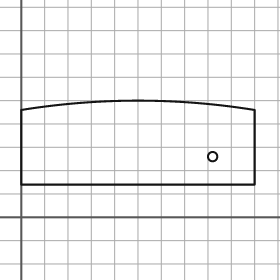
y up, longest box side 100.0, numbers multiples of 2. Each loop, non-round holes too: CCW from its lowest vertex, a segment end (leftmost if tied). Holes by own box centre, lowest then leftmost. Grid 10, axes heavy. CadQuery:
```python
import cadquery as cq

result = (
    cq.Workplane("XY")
    .moveTo(0.0, 14.0)
    .lineTo(100.0, 14.0)
    .lineTo(100.0, 46.0)
    .threePointArc((50.0, 50.0), (0.0, 46.0))
    .close()
    .moveTo(82.0, 26.0)
    .circle(2.0)
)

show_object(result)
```